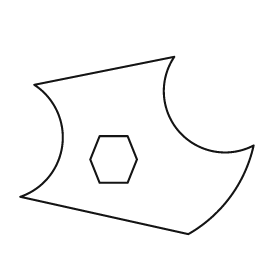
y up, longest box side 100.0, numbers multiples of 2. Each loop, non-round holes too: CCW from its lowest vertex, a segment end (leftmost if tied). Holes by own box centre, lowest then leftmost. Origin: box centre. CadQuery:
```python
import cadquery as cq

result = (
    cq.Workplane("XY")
    .moveTo(22.0, -38.0)
    .threePointArc((40.0, -22.0), (50.0, 0.0))
    .threePointArc((18.0, 6.0), (16.0, 38.0))
    .lineTo(-44.0, 26.0)
    .threePointArc((-32.0, 0.0), (-50.0, -22.0))
    .close()
    .moveTo(-16.0, -16.0)
    .lineTo(-4.0, -16.0)
    .lineTo(0.0, -6.0)
    .lineTo(-4.0, 4.0)
    .lineTo(-16.0, 4.0)
    .lineTo(-20.0, -6.0)
    .close()
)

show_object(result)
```